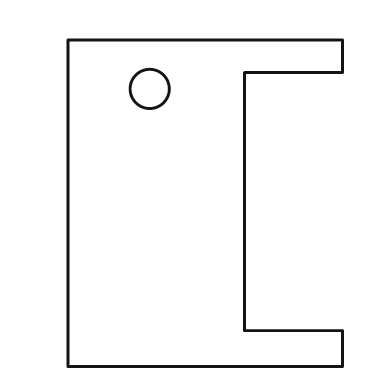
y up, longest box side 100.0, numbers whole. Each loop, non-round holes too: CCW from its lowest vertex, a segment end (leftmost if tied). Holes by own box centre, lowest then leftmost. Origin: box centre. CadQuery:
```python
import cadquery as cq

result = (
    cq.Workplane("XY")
    .moveTo(-42.0, -50.0)
    .lineTo(42.0, -50.0)
    .lineTo(42.0, -39.0)
    .lineTo(12.0, -39.0)
    .lineTo(12.0, 40.0)
    .lineTo(42.0, 40.0)
    .lineTo(42.0, 50.0)
    .lineTo(-42.0, 50.0)
    .close()
    .moveTo(-17.0, 35.0)
    .circle(6.0)
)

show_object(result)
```